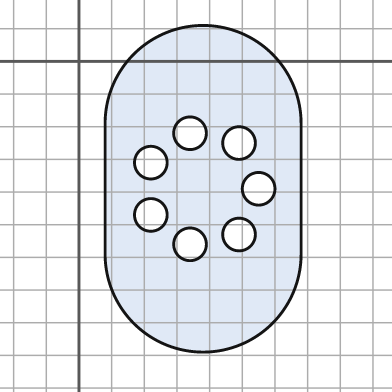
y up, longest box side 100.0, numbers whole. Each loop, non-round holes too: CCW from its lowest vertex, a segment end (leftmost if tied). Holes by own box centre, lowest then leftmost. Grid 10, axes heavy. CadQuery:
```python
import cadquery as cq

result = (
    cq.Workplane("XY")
    .moveTo(8.0, -59.0)
    .threePointArc((38.0, -89.0), (68.0, -59.0))
    .lineTo(68.0, -19.0)
    .threePointArc((38.0, 11.0), (8.0, -19.0))
    .close()
    .moveTo(34.0, -56.0)
    .circle(5.0)
    .moveTo(49.0, -53.0)
    .circle(5.0)
    .moveTo(22.0, -47.0)
    .circle(5.0)
    .moveTo(55.0, -39.0)
    .circle(5.0)
    .moveTo(22.0, -31.0)
    .circle(5.0)
    .moveTo(49.0, -25.0)
    .circle(5.0)
    .moveTo(34.0, -22.0)
    .circle(5.0)
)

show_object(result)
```